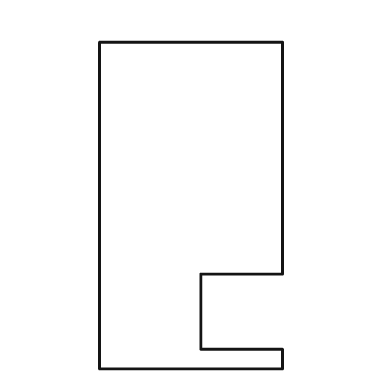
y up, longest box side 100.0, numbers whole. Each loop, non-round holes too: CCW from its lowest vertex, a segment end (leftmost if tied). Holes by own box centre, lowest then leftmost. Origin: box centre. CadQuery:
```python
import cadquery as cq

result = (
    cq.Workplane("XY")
    .moveTo(-28.0, -50.0)
    .lineTo(28.0, -50.0)
    .lineTo(28.0, -44.0)
    .lineTo(3.0, -44.0)
    .lineTo(3.0, -21.0)
    .lineTo(28.0, -21.0)
    .lineTo(28.0, 50.0)
    .lineTo(-28.0, 50.0)
    .close()
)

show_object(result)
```